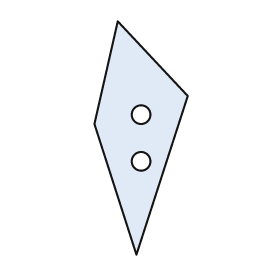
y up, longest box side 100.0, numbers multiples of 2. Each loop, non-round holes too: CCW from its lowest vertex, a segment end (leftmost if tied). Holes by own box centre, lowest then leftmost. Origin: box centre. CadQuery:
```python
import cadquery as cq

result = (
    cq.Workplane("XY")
    .moveTo(-2.0, -50.0)
    .lineTo(20.0, 18.0)
    .lineTo(-10.0, 50.0)
    .lineTo(-20.0, 6.0)
    .close()
    .moveTo(0.0, -10.0)
    .circle(4.0)
    .moveTo(0.0, 10.0)
    .circle(4.0)
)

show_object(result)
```